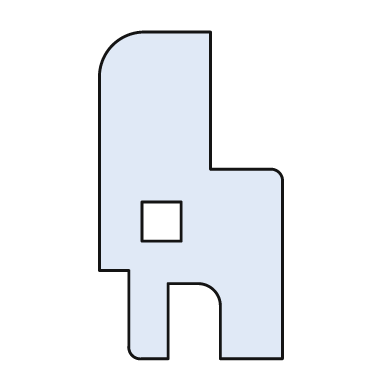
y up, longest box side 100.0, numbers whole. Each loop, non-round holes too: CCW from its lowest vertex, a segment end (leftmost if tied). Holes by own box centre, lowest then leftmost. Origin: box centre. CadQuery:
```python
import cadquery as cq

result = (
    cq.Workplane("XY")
    .moveTo(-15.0, -50.0)
    .lineTo(-7.0, -50.0)
    .lineTo(-7.0, -27.0)
    .lineTo(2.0, -27.0)
    .threePointArc((7.0, -29.0), (9.0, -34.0))
    .lineTo(9.0, -50.0)
    .lineTo(28.0, -50.0)
    .lineTo(28.0, 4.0)
    .threePointArc((27.0, 7.0), (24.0, 8.0))
    .lineTo(6.0, 8.0)
    .lineTo(6.0, 50.0)
    .lineTo(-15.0, 50.0)
    .threePointArc((-24.0, 46.0), (-28.0, 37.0))
    .lineTo(-28.0, -23.0)
    .lineTo(-19.0, -23.0)
    .lineTo(-19.0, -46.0)
    .threePointArc((-18.0, -49.0), (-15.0, -50.0))
    .close()
    .moveTo(-15.0, -14.0)
    .lineTo(-3.0, -14.0)
    .lineTo(-3.0, -2.0)
    .lineTo(-15.0, -2.0)
    .close()
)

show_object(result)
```